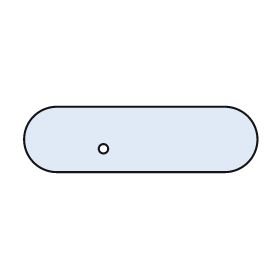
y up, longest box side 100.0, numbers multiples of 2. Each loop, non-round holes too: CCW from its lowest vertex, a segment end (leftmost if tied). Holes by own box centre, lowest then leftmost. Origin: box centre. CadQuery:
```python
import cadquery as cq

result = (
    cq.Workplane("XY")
    .moveTo(-36.0, -14.0)
    .lineTo(36.0, -14.0)
    .threePointArc((50.0, 0.0), (36.0, 14.0))
    .lineTo(-36.0, 14.0)
    .threePointArc((-50.0, 0.0), (-36.0, -14.0))
    .close()
    .moveTo(-16.0, -4.0)
    .circle(2.0)
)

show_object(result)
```